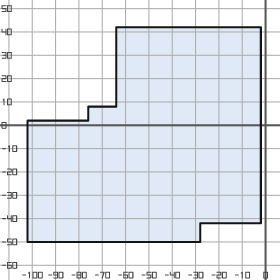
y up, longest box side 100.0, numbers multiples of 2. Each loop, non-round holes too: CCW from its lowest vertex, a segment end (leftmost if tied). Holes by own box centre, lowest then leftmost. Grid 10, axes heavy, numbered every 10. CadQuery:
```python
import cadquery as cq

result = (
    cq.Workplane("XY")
    .moveTo(-102.0, -50.0)
    .lineTo(-28.0, -50.0)
    .lineTo(-28.0, -42.0)
    .lineTo(-2.0, -42.0)
    .lineTo(-2.0, 42.0)
    .lineTo(-64.0, 42.0)
    .lineTo(-64.0, 8.0)
    .lineTo(-76.0, 8.0)
    .lineTo(-76.0, 2.0)
    .lineTo(-102.0, 2.0)
    .close()
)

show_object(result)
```